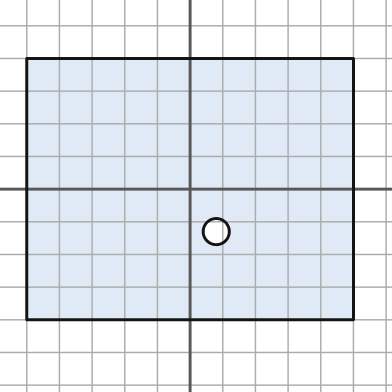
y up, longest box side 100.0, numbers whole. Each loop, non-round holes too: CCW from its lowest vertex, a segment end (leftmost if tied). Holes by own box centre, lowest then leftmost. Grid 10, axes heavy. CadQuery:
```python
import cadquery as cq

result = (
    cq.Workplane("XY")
    .moveTo(-50.0, -40.0)
    .lineTo(50.0, -40.0)
    .lineTo(50.0, 40.0)
    .lineTo(-50.0, 40.0)
    .close()
    .moveTo(8.0, -13.0)
    .circle(4.0)
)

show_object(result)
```